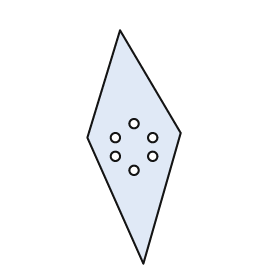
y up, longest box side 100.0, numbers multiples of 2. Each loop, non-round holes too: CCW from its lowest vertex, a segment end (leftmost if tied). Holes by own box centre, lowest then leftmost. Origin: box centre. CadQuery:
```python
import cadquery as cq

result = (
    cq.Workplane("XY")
    .moveTo(4.0, -50.0)
    .lineTo(20.0, 6.0)
    .lineTo(-6.0, 50.0)
    .lineTo(-20.0, 4.0)
    .close()
    .moveTo(0.0, -10.0)
    .circle(2.0)
    .moveTo(-8.0, -4.0)
    .circle(2.0)
    .moveTo(8.0, -4.0)
    .circle(2.0)
    .moveTo(-8.0, 4.0)
    .circle(2.0)
    .moveTo(8.0, 4.0)
    .circle(2.0)
    .moveTo(0.0, 10.0)
    .circle(2.0)
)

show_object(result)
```